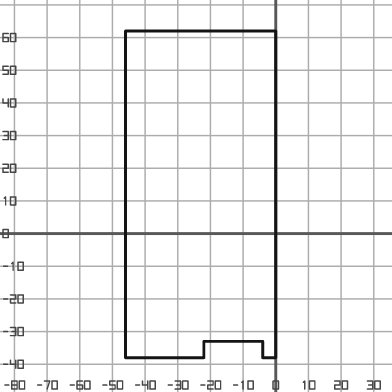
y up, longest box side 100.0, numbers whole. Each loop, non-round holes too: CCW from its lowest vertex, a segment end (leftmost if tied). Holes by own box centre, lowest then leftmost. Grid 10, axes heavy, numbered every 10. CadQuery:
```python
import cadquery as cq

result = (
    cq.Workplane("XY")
    .moveTo(-46.0, -38.0)
    .lineTo(-22.0, -38.0)
    .lineTo(-22.0, -33.0)
    .lineTo(-4.0, -33.0)
    .lineTo(-4.0, -38.0)
    .lineTo(0.0, -38.0)
    .lineTo(0.0, 62.0)
    .lineTo(-46.0, 62.0)
    .close()
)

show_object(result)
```